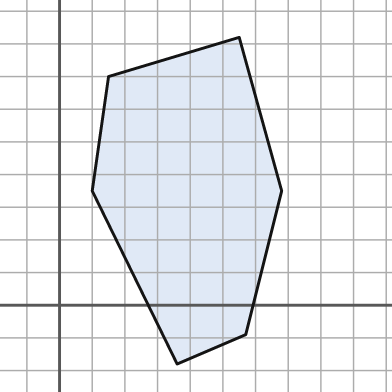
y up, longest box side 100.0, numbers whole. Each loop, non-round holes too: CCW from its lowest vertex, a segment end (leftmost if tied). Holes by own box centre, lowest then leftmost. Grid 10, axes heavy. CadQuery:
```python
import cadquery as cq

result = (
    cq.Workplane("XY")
    .moveTo(36.0, -18.0)
    .lineTo(57.0, -9.0)
    .lineTo(68.0, 35.0)
    .lineTo(55.0, 82.0)
    .lineTo(15.0, 70.0)
    .lineTo(10.0, 35.0)
    .close()
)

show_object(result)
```